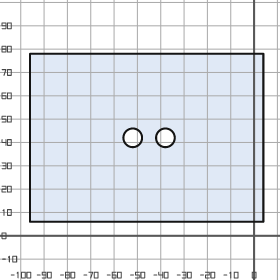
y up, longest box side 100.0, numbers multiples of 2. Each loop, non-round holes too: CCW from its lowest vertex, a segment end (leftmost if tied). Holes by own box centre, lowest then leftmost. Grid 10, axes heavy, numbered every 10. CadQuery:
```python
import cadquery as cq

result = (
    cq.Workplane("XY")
    .moveTo(-96.0, 6.0)
    .lineTo(4.0, 6.0)
    .lineTo(4.0, 78.0)
    .lineTo(-96.0, 78.0)
    .close()
    .moveTo(-52.0, 42.0)
    .circle(4.0)
    .moveTo(-38.0, 42.0)
    .circle(4.0)
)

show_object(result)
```